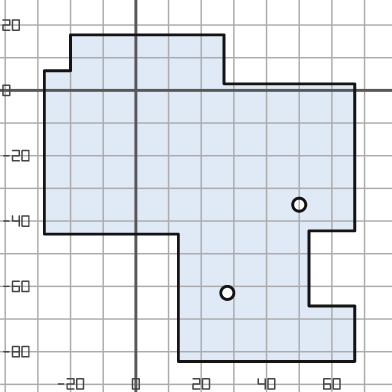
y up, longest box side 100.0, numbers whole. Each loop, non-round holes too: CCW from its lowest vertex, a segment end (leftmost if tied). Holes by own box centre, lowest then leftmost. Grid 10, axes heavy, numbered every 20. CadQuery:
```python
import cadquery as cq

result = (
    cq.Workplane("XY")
    .moveTo(13.0, -83.0)
    .lineTo(67.0, -83.0)
    .lineTo(67.0, -66.0)
    .lineTo(53.0, -66.0)
    .lineTo(53.0, -43.0)
    .lineTo(67.0, -43.0)
    .lineTo(67.0, 2.0)
    .lineTo(27.0, 2.0)
    .lineTo(27.0, 17.0)
    .lineTo(-20.0, 17.0)
    .lineTo(-20.0, 6.0)
    .lineTo(-28.0, 6.0)
    .lineTo(-28.0, -44.0)
    .lineTo(13.0, -44.0)
    .close()
    .moveTo(28.0, -62.0)
    .circle(2.0)
    .moveTo(50.0, -35.0)
    .circle(2.0)
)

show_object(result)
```